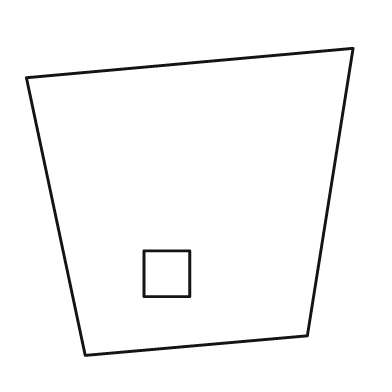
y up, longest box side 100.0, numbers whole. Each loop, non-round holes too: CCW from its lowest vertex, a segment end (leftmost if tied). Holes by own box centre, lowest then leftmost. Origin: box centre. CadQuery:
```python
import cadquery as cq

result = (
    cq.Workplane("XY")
    .moveTo(-32.0, -47.0)
    .lineTo(36.0, -41.0)
    .lineTo(50.0, 47.0)
    .lineTo(-50.0, 38.0)
    .close()
    .moveTo(-14.0, -29.0)
    .lineTo(0.0, -29.0)
    .lineTo(0.0, -15.0)
    .lineTo(-14.0, -15.0)
    .close()
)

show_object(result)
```